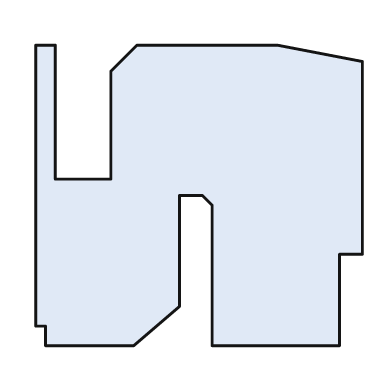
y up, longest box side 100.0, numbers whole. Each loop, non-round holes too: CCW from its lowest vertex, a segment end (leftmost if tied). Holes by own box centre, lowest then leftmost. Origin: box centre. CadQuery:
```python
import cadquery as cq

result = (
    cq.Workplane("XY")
    .moveTo(-47.0, -46.0)
    .lineTo(-20.0, -46.0)
    .lineTo(-6.0, -34.0)
    .lineTo(-6.0, 0.0)
    .lineTo(1.0, 0.0)
    .lineTo(4.0, -3.0)
    .lineTo(4.0, -46.0)
    .lineTo(43.0, -46.0)
    .lineTo(43.0, -18.0)
    .lineTo(50.0, -18.0)
    .lineTo(50.0, 41.0)
    .lineTo(24.0, 46.0)
    .lineTo(-19.0, 46.0)
    .lineTo(-27.0, 38.0)
    .lineTo(-27.0, 5.0)
    .lineTo(-44.0, 5.0)
    .lineTo(-44.0, 46.0)
    .lineTo(-50.0, 46.0)
    .lineTo(-50.0, -40.0)
    .lineTo(-47.0, -40.0)
    .close()
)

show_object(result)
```